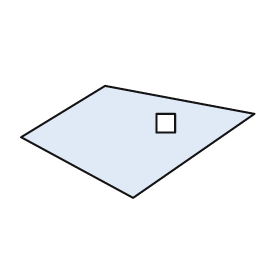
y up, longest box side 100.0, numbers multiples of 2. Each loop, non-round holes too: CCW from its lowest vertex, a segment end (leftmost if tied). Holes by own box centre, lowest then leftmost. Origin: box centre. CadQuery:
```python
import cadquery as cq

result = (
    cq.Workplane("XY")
    .moveTo(-2.0, -24.0)
    .lineTo(50.0, 12.0)
    .lineTo(-14.0, 24.0)
    .lineTo(-50.0, 2.0)
    .close()
    .moveTo(8.0, 4.0)
    .lineTo(16.0, 4.0)
    .lineTo(16.0, 12.0)
    .lineTo(8.0, 12.0)
    .close()
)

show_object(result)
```